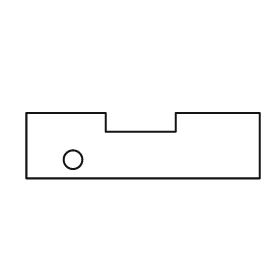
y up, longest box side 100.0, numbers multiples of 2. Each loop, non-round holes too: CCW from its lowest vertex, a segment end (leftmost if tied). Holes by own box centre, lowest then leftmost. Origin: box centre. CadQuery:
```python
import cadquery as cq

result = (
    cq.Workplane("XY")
    .moveTo(-50.0, -14.0)
    .lineTo(50.0, -14.0)
    .lineTo(50.0, 14.0)
    .lineTo(14.0, 14.0)
    .lineTo(14.0, 6.0)
    .lineTo(-16.0, 6.0)
    .lineTo(-16.0, 14.0)
    .lineTo(-50.0, 14.0)
    .close()
    .moveTo(-30.0, -6.0)
    .circle(4.0)
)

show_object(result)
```